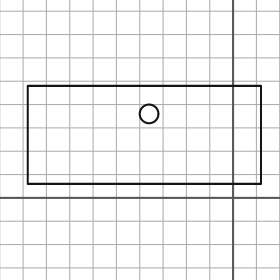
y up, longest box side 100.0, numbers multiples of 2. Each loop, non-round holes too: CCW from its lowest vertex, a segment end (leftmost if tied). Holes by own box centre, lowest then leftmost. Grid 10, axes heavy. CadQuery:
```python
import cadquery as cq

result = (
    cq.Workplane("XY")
    .moveTo(-88.0, 6.0)
    .lineTo(12.0, 6.0)
    .lineTo(12.0, 48.0)
    .lineTo(-88.0, 48.0)
    .close()
    .moveTo(-36.0, 36.0)
    .circle(4.0)
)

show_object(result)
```